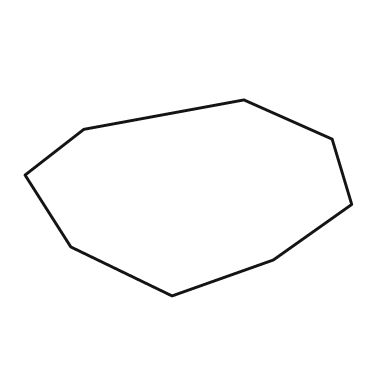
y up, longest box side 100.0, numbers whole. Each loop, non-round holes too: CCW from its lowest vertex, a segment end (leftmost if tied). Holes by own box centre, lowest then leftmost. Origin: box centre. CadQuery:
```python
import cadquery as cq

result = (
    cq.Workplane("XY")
    .moveTo(-5.0, -30.0)
    .lineTo(26.0, -19.0)
    .lineTo(50.0, -2.0)
    .lineTo(44.0, 18.0)
    .lineTo(17.0, 30.0)
    .lineTo(-32.0, 21.0)
    .lineTo(-50.0, 7.0)
    .lineTo(-36.0, -15.0)
    .close()
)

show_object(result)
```